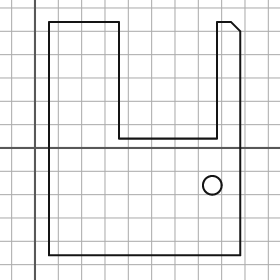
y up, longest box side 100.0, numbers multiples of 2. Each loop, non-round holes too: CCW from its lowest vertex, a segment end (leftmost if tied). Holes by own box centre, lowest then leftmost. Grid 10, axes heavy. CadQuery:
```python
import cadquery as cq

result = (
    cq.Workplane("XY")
    .moveTo(6.0, -46.0)
    .lineTo(88.0, -46.0)
    .lineTo(88.0, 50.0)
    .lineTo(84.0, 54.0)
    .lineTo(78.0, 54.0)
    .lineTo(78.0, 4.0)
    .lineTo(36.0, 4.0)
    .lineTo(36.0, 54.0)
    .lineTo(6.0, 54.0)
    .close()
    .moveTo(76.0, -16.0)
    .circle(4.0)
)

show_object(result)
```